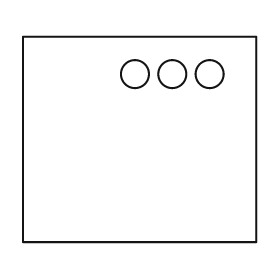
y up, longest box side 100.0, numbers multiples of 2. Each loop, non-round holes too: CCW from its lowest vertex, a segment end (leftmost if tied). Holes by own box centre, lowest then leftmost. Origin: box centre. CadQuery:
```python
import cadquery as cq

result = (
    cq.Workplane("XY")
    .moveTo(-50.0, -44.0)
    .lineTo(50.0, -44.0)
    .lineTo(50.0, 44.0)
    .lineTo(-50.0, 44.0)
    .close()
    .moveTo(-2.0, 28.0)
    .circle(6.0)
    .moveTo(14.0, 28.0)
    .circle(6.0)
    .moveTo(30.0, 28.0)
    .circle(6.0)
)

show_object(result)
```